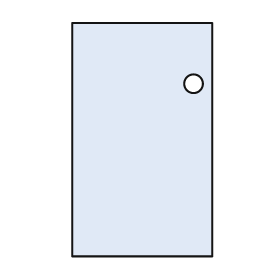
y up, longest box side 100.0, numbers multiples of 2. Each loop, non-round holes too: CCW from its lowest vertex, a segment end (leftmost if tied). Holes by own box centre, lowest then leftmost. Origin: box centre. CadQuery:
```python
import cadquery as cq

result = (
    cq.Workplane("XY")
    .moveTo(-30.0, -50.0)
    .lineTo(30.0, -50.0)
    .lineTo(30.0, 50.0)
    .lineTo(-30.0, 50.0)
    .close()
    .moveTo(22.0, 24.0)
    .circle(4.0)
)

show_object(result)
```